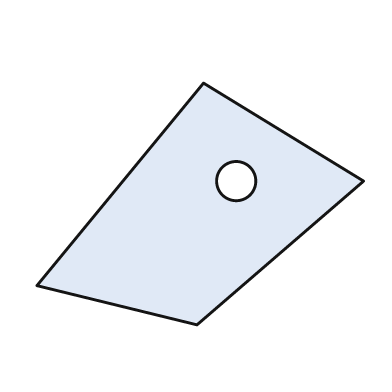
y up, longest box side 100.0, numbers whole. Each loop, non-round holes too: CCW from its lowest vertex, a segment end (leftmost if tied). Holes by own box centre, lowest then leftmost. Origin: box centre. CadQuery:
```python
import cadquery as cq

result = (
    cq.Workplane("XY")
    .moveTo(-1.0, -37.0)
    .lineTo(50.0, 7.0)
    .lineTo(1.0, 37.0)
    .lineTo(-50.0, -25.0)
    .close()
    .moveTo(11.0, 7.0)
    .circle(6.0)
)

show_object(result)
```